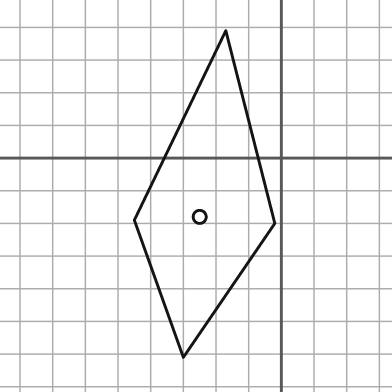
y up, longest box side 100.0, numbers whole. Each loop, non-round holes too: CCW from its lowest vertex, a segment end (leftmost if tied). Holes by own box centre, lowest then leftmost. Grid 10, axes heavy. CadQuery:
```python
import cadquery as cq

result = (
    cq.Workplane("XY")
    .moveTo(-30.0, -61.0)
    .lineTo(-2.0, -20.0)
    .lineTo(-17.0, 39.0)
    .lineTo(-45.0, -19.0)
    .close()
    .moveTo(-25.0, -18.0)
    .circle(2.0)
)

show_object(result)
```